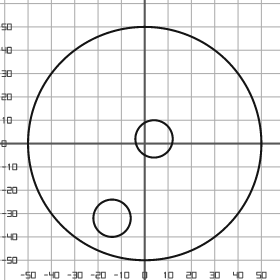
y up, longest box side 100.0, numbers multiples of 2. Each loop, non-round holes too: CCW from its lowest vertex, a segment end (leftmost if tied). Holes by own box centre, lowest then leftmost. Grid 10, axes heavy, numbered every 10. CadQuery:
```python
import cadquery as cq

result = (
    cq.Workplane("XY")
    .moveTo(0.0, 0.0)
    .circle(50.0)
    .moveTo(-14.0, -32.0)
    .circle(8.0)
    .moveTo(4.0, 2.0)
    .circle(8.0)
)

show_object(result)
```